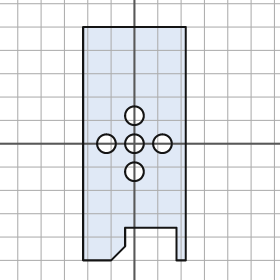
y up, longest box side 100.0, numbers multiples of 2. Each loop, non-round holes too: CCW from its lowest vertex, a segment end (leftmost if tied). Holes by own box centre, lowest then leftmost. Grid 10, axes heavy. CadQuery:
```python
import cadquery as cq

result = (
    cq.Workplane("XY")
    .moveTo(-22.0, -50.0)
    .lineTo(-10.0, -50.0)
    .lineTo(-4.0, -44.0)
    .lineTo(-4.0, -36.0)
    .lineTo(18.0, -36.0)
    .lineTo(18.0, -50.0)
    .lineTo(22.0, -50.0)
    .lineTo(22.0, 50.0)
    .lineTo(-22.0, 50.0)
    .close()
    .moveTo(0.0, -12.0)
    .circle(4.0)
    .moveTo(-12.0, 0.0)
    .circle(4.0)
    .moveTo(0.0, 0.0)
    .circle(4.0)
    .moveTo(12.0, 0.0)
    .circle(4.0)
    .moveTo(0.0, 12.0)
    .circle(4.0)
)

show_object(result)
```